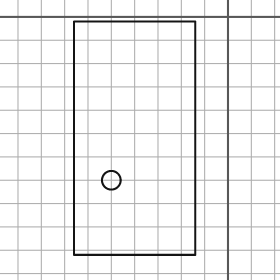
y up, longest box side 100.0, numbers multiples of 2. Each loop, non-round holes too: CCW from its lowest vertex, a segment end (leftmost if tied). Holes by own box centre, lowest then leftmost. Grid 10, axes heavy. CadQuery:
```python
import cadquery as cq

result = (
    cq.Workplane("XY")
    .moveTo(-66.0, -102.0)
    .lineTo(-14.0, -102.0)
    .lineTo(-14.0, -2.0)
    .lineTo(-66.0, -2.0)
    .close()
    .moveTo(-50.0, -70.0)
    .circle(4.0)
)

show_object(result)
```